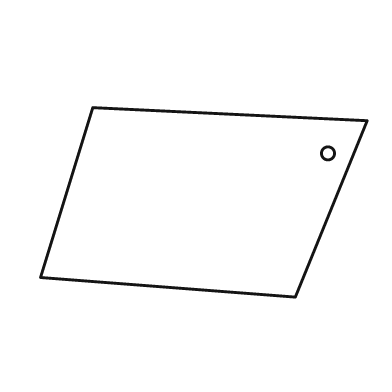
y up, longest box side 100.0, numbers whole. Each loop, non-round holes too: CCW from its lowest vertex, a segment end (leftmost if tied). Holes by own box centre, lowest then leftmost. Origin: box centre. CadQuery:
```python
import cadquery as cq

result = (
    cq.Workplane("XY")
    .moveTo(28.0, -29.0)
    .lineTo(50.0, 25.0)
    .lineTo(-34.0, 29.0)
    .lineTo(-50.0, -23.0)
    .close()
    .moveTo(38.0, 15.0)
    .circle(2.0)
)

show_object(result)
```